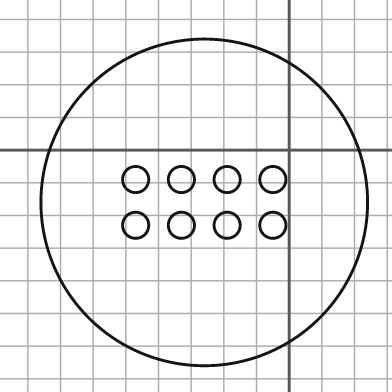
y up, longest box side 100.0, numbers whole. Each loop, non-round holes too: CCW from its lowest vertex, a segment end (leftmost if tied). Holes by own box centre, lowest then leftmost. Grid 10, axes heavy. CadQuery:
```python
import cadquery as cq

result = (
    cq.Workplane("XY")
    .moveTo(-26.0, -16.0)
    .circle(50.0)
    .moveTo(-47.0, -23.0)
    .circle(4.0)
    .moveTo(-33.0, -23.0)
    .circle(4.0)
    .moveTo(-19.0, -23.0)
    .circle(4.0)
    .moveTo(-5.0, -23.0)
    .circle(4.0)
    .moveTo(-47.0, -9.0)
    .circle(4.0)
    .moveTo(-33.0, -9.0)
    .circle(4.0)
    .moveTo(-19.0, -9.0)
    .circle(4.0)
    .moveTo(-5.0, -9.0)
    .circle(4.0)
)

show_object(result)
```